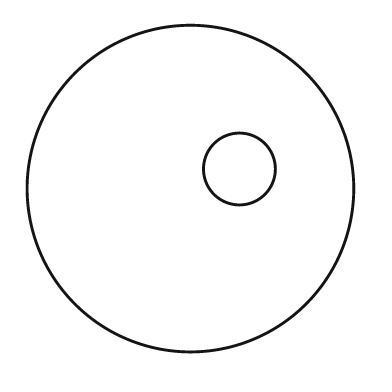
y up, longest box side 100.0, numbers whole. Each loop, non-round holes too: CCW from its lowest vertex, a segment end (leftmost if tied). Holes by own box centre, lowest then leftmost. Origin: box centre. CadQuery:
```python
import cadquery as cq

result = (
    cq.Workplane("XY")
    .moveTo(0.0, 0.0)
    .circle(50.0)
    .moveTo(15.0, 6.0)
    .circle(11.0)
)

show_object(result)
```